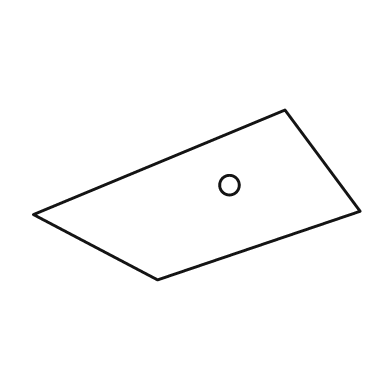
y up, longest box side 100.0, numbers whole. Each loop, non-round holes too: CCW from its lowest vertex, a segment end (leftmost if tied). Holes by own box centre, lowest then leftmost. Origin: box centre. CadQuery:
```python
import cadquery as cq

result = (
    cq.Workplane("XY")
    .moveTo(-12.0, -26.0)
    .lineTo(50.0, -5.0)
    .lineTo(27.0, 26.0)
    .lineTo(-50.0, -6.0)
    .close()
    .moveTo(10.0, 3.0)
    .circle(3.0)
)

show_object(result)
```